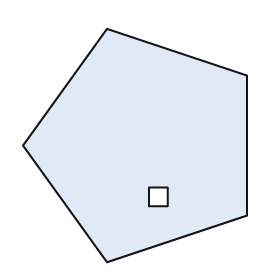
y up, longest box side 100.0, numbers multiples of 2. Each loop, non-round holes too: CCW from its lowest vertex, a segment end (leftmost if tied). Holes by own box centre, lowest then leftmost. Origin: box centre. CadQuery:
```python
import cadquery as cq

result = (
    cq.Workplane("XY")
    .moveTo(-12.0, -50.0)
    .lineTo(48.0, -30.0)
    .lineTo(48.0, 30.0)
    .lineTo(-12.0, 50.0)
    .lineTo(-48.0, 0.0)
    .close()
    .moveTo(6.0, -26.0)
    .lineTo(14.0, -26.0)
    .lineTo(14.0, -18.0)
    .lineTo(6.0, -18.0)
    .close()
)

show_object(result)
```